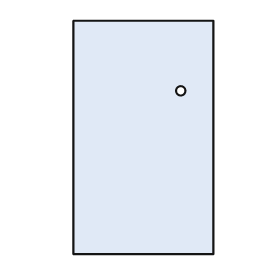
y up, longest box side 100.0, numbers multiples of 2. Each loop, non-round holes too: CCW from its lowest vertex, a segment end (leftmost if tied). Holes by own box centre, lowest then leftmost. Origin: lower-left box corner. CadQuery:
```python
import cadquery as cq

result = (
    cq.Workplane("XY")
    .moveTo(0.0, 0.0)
    .lineTo(60.0, 0.0)
    .lineTo(60.0, 100.0)
    .lineTo(0.0, 100.0)
    .close()
    .moveTo(46.0, 70.0)
    .circle(2.0)
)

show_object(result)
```